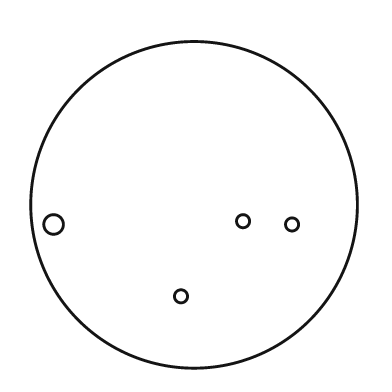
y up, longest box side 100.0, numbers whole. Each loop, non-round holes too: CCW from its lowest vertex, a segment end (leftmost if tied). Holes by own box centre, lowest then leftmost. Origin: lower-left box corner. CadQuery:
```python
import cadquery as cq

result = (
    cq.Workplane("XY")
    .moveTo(50.0, 50.0)
    .circle(50.0)
    .moveTo(46.0, 22.0)
    .circle(2.0)
    .moveTo(7.0, 44.0)
    .circle(3.0)
    .moveTo(80.0, 44.0)
    .circle(2.0)
    .moveTo(65.0, 45.0)
    .circle(2.0)
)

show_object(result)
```